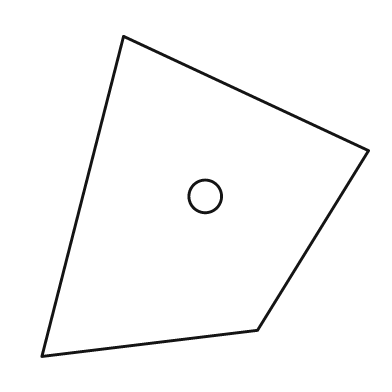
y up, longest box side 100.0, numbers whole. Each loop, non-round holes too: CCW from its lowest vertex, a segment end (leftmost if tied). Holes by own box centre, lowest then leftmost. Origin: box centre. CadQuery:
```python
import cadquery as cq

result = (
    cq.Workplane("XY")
    .moveTo(-50.0, -49.0)
    .lineTo(16.0, -41.0)
    .lineTo(50.0, 14.0)
    .lineTo(-25.0, 49.0)
    .close()
    .moveTo(0.0, 0.0)
    .circle(5.0)
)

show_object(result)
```